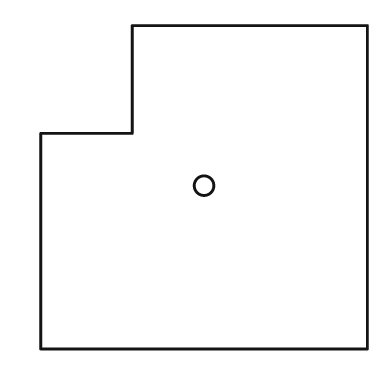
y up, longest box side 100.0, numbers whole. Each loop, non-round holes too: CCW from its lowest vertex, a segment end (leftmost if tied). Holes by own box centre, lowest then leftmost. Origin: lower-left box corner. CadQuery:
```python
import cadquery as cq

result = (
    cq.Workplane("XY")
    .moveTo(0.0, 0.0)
    .lineTo(100.0, 0.0)
    .lineTo(100.0, 99.0)
    .lineTo(28.0, 99.0)
    .lineTo(28.0, 66.0)
    .lineTo(0.0, 66.0)
    .close()
    .moveTo(50.0, 50.0)
    .circle(3.0)
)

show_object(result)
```